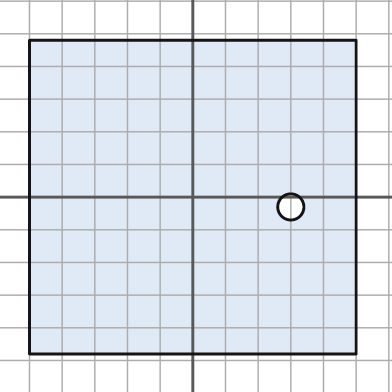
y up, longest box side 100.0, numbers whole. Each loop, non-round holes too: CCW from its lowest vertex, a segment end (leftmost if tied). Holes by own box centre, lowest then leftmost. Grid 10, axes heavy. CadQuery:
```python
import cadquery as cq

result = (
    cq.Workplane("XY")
    .moveTo(-50.0, -48.0)
    .lineTo(50.0, -48.0)
    .lineTo(50.0, 48.0)
    .lineTo(-50.0, 48.0)
    .close()
    .moveTo(30.0, -3.0)
    .circle(4.0)
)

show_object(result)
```